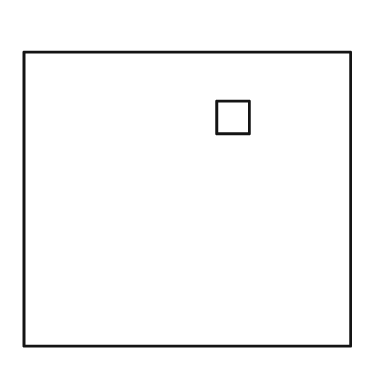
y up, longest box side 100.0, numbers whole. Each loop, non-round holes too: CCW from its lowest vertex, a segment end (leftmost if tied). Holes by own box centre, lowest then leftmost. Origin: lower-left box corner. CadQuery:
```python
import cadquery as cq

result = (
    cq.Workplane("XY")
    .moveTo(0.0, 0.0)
    .lineTo(100.0, 0.0)
    .lineTo(100.0, 90.0)
    .lineTo(0.0, 90.0)
    .close()
    .moveTo(59.0, 65.0)
    .lineTo(69.0, 65.0)
    .lineTo(69.0, 75.0)
    .lineTo(59.0, 75.0)
    .close()
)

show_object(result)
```